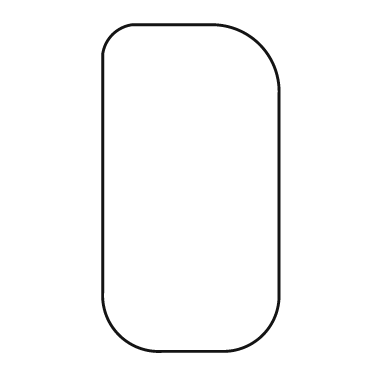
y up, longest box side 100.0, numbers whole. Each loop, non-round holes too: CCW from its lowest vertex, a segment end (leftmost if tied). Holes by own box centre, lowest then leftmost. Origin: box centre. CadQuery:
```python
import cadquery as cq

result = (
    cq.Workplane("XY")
    .moveTo(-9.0, -50.0)
    .lineTo(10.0, -50.0)
    .threePointArc((22.0, -45.0), (27.0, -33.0))
    .lineTo(27.0, 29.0)
    .threePointArc((21.0, 44.0), (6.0, 50.0))
    .lineTo(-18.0, 50.0)
    .threePointArc((-24.0, 47.0), (-27.0, 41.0))
    .lineTo(-27.0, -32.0)
    .threePointArc((-22.0, -45.0), (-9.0, -50.0))
    .close()
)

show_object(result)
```